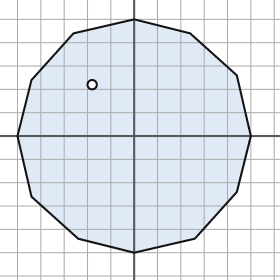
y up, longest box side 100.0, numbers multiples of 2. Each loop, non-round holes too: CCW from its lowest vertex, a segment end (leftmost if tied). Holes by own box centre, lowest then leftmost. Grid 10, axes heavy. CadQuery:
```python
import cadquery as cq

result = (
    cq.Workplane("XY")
    .moveTo(0.0, -50.0)
    .lineTo(26.0, -44.0)
    .lineTo(44.0, -24.0)
    .lineTo(50.0, 0.0)
    .lineTo(44.0, 26.0)
    .lineTo(24.0, 44.0)
    .lineTo(0.0, 50.0)
    .lineTo(-26.0, 44.0)
    .lineTo(-44.0, 24.0)
    .lineTo(-50.0, 0.0)
    .lineTo(-44.0, -26.0)
    .lineTo(-24.0, -44.0)
    .close()
    .moveTo(-18.0, 22.0)
    .circle(2.0)
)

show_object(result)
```